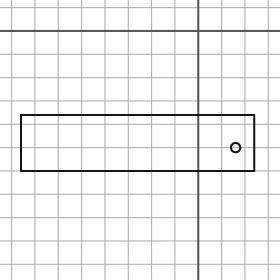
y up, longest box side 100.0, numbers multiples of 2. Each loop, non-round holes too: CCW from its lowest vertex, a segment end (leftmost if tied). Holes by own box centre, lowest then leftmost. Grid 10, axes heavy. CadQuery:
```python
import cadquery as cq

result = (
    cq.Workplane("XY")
    .moveTo(-76.0, -60.0)
    .lineTo(24.0, -60.0)
    .lineTo(24.0, -36.0)
    .lineTo(-76.0, -36.0)
    .close()
    .moveTo(16.0, -50.0)
    .circle(2.0)
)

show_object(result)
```